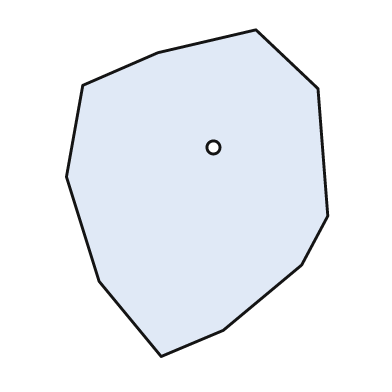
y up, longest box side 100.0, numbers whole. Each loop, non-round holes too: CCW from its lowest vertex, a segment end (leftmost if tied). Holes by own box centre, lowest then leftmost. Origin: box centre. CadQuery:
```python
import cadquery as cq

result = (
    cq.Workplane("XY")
    .moveTo(-11.0, -50.0)
    .lineTo(8.0, -42.0)
    .lineTo(32.0, -22.0)
    .lineTo(40.0, -7.0)
    .lineTo(37.0, 32.0)
    .lineTo(18.0, 50.0)
    .lineTo(-12.0, 43.0)
    .lineTo(-35.0, 33.0)
    .lineTo(-40.0, 5.0)
    .lineTo(-30.0, -27.0)
    .close()
    .moveTo(5.0, 14.0)
    .circle(2.0)
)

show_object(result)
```